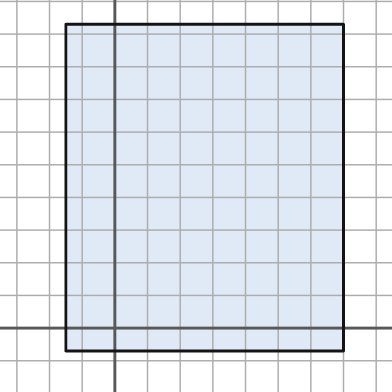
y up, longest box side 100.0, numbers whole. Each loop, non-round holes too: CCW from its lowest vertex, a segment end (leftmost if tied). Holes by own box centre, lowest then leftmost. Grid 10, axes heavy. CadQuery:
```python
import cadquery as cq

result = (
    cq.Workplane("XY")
    .moveTo(-15.0, -7.0)
    .lineTo(70.0, -7.0)
    .lineTo(70.0, 93.0)
    .lineTo(-15.0, 93.0)
    .close()
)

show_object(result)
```